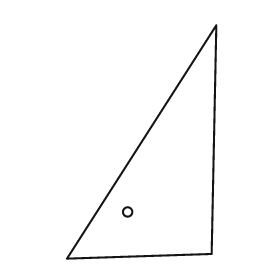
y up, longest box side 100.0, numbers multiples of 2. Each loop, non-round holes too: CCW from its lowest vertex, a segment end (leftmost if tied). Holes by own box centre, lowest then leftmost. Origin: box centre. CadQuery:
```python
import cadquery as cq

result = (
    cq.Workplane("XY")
    .moveTo(-32.0, -50.0)
    .lineTo(30.0, -48.0)
    .lineTo(32.0, 50.0)
    .close()
    .moveTo(-6.0, -30.0)
    .circle(2.0)
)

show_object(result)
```